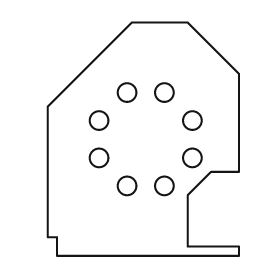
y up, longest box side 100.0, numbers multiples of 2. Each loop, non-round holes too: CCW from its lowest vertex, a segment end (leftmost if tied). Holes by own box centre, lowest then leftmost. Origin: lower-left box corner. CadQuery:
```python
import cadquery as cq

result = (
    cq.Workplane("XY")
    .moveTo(4.0, 0.0)
    .lineTo(82.0, 0.0)
    .lineTo(82.0, 4.0)
    .lineTo(60.0, 4.0)
    .lineTo(60.0, 26.0)
    .lineTo(70.0, 36.0)
    .lineTo(82.0, 36.0)
    .lineTo(82.0, 78.0)
    .lineTo(60.0, 100.0)
    .lineTo(36.0, 100.0)
    .lineTo(0.0, 64.0)
    .lineTo(0.0, 8.0)
    .lineTo(4.0, 8.0)
    .close()
    .moveTo(34.0, 30.0)
    .circle(4.0)
    .moveTo(50.0, 30.0)
    .circle(4.0)
    .moveTo(22.0, 42.0)
    .circle(4.0)
    .moveTo(62.0, 42.0)
    .circle(4.0)
    .moveTo(22.0, 58.0)
    .circle(4.0)
    .moveTo(62.0, 58.0)
    .circle(4.0)
    .moveTo(34.0, 70.0)
    .circle(4.0)
    .moveTo(50.0, 70.0)
    .circle(4.0)
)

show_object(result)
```